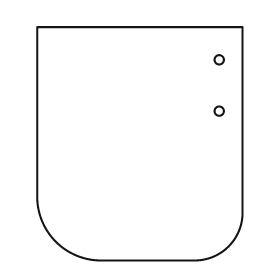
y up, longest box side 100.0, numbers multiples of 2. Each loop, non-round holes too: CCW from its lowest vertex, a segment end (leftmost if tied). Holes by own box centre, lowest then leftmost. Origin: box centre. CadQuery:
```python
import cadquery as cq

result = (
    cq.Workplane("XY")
    .moveTo(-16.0, -50.0)
    .lineTo(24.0, -50.0)
    .threePointArc((38.0, -44.0), (44.0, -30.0))
    .lineTo(44.0, 50.0)
    .lineTo(-44.0, 50.0)
    .lineTo(-44.0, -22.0)
    .threePointArc((-36.0, -42.0), (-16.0, -50.0))
    .close()
    .moveTo(34.0, 14.0)
    .circle(2.0)
    .moveTo(34.0, 36.0)
    .circle(2.0)
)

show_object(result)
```